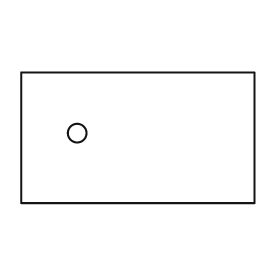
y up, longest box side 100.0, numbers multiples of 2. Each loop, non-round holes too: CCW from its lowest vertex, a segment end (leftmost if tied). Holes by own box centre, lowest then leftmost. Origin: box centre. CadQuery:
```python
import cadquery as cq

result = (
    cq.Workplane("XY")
    .moveTo(-50.0, -28.0)
    .lineTo(50.0, -28.0)
    .lineTo(50.0, 28.0)
    .lineTo(-50.0, 28.0)
    .close()
    .moveTo(-26.0, 2.0)
    .circle(4.0)
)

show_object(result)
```